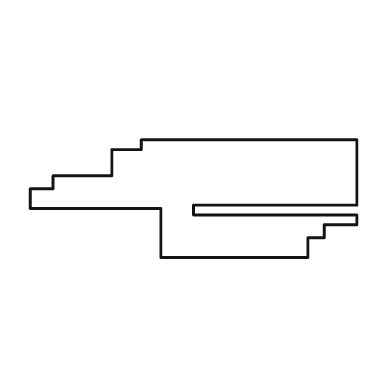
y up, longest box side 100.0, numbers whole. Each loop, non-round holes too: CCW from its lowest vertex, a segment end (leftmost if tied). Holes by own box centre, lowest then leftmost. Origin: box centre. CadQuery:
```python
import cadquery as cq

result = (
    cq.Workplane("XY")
    .moveTo(-10.0, -18.0)
    .lineTo(35.0, -18.0)
    .lineTo(35.0, -12.0)
    .lineTo(40.0, -12.0)
    .lineTo(40.0, -8.0)
    .lineTo(50.0, -8.0)
    .lineTo(50.0, -5.0)
    .lineTo(0.0, -5.0)
    .lineTo(0.0, -2.0)
    .lineTo(50.0, -2.0)
    .lineTo(50.0, 18.0)
    .lineTo(-16.0, 18.0)
    .lineTo(-16.0, 15.0)
    .lineTo(-25.0, 15.0)
    .lineTo(-25.0, 7.0)
    .lineTo(-43.0, 7.0)
    .lineTo(-43.0, 3.0)
    .lineTo(-50.0, 3.0)
    .lineTo(-50.0, -3.0)
    .lineTo(-10.0, -3.0)
    .close()
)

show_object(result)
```